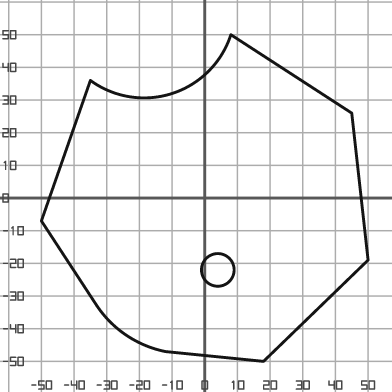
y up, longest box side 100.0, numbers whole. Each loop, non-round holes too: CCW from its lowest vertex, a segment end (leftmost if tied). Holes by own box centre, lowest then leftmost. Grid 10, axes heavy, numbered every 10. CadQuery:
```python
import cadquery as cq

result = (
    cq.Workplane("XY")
    .moveTo(18.0, -50.0)
    .lineTo(50.0, -19.0)
    .lineTo(45.0, 26.0)
    .lineTo(8.0, 50.0)
    .threePointArc((-10.0, 32.0), (-35.0, 36.0))
    .lineTo(-50.0, -7.0)
    .lineTo(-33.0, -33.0)
    .threePointArc((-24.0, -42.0), (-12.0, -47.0))
    .close()
    .moveTo(4.0, -22.0)
    .circle(5.0)
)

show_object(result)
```